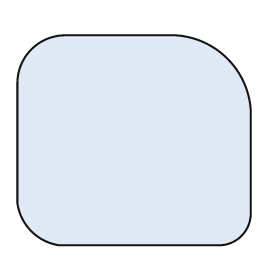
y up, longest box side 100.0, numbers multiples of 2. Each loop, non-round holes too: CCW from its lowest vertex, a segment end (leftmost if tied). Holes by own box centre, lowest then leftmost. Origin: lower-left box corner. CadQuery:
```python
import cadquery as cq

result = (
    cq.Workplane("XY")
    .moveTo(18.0, 0.0)
    .lineTo(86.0, 0.0)
    .threePointArc((96.0, 4.0), (100.0, 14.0))
    .lineTo(100.0, 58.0)
    .threePointArc((90.0, 80.0), (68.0, 90.0))
    .lineTo(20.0, 90.0)
    .threePointArc((6.0, 84.0), (0.0, 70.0))
    .lineTo(0.0, 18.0)
    .threePointArc((6.0, 6.0), (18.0, 0.0))
    .close()
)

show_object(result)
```